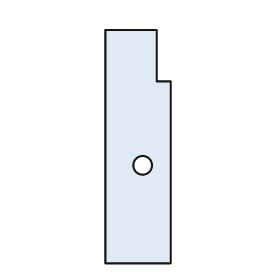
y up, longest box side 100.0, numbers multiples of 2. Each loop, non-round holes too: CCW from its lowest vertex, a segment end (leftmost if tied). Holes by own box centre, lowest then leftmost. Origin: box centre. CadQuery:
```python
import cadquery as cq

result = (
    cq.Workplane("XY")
    .moveTo(-14.0, -50.0)
    .lineTo(14.0, -50.0)
    .lineTo(14.0, 28.0)
    .lineTo(8.0, 28.0)
    .lineTo(8.0, 50.0)
    .lineTo(-14.0, 50.0)
    .close()
    .moveTo(2.0, -8.0)
    .circle(4.0)
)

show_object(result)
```